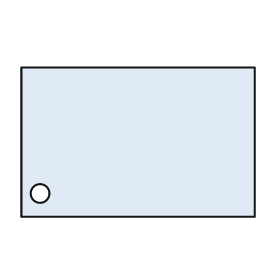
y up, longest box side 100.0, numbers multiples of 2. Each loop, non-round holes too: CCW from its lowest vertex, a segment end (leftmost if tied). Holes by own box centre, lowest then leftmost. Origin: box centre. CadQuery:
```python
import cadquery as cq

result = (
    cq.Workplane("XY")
    .moveTo(-50.0, -32.0)
    .lineTo(50.0, -32.0)
    .lineTo(50.0, 32.0)
    .lineTo(-50.0, 32.0)
    .close()
    .moveTo(-42.0, -22.0)
    .circle(4.0)
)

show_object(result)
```